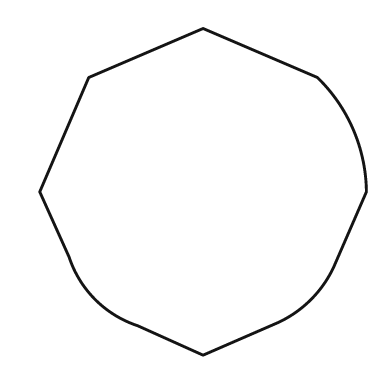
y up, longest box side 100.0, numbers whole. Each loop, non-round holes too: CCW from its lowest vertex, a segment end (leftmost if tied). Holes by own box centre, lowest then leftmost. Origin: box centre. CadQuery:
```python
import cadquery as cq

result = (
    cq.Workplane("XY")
    .moveTo(0.0, -50.0)
    .lineTo(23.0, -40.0)
    .threePointArc((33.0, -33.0), (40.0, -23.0))
    .lineTo(50.0, 0.0)
    .threePointArc((46.0, 19.0), (35.0, 35.0))
    .lineTo(0.0, 50.0)
    .lineTo(-35.0, 35.0)
    .lineTo(-50.0, 0.0)
    .lineTo(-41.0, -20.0)
    .threePointArc((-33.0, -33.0), (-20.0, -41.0))
    .close()
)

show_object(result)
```